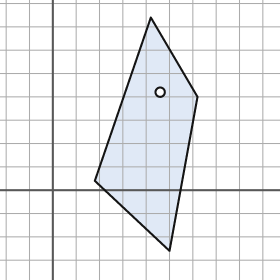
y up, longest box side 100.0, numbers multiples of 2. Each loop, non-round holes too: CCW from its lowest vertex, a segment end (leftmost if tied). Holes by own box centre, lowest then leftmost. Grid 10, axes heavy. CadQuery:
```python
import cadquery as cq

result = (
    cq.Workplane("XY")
    .moveTo(50.0, -26.0)
    .lineTo(62.0, 40.0)
    .lineTo(42.0, 74.0)
    .lineTo(18.0, 4.0)
    .close()
    .moveTo(46.0, 42.0)
    .circle(2.0)
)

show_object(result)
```